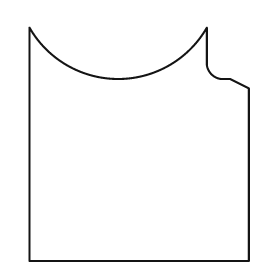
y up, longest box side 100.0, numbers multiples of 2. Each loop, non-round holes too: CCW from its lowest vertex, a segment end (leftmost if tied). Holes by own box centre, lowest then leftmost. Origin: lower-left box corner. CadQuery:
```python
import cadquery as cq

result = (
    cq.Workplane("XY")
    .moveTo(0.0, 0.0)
    .lineTo(94.0, 0.0)
    .lineTo(94.0, 74.0)
    .lineTo(86.0, 78.0)
    .lineTo(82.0, 78.0)
    .threePointArc((78.0, 80.0), (76.0, 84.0))
    .lineTo(76.0, 100.0)
    .threePointArc((38.0, 78.0), (0.0, 100.0))
    .close()
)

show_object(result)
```